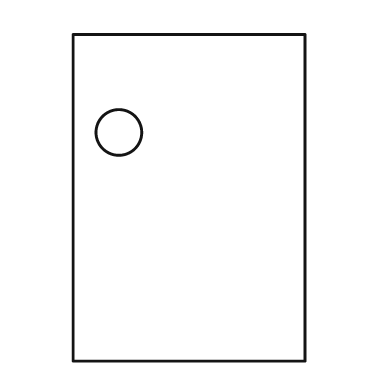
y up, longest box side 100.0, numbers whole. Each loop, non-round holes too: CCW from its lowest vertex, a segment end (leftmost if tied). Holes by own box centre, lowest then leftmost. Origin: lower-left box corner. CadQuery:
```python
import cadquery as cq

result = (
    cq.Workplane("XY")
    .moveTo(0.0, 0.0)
    .lineTo(71.0, 0.0)
    .lineTo(71.0, 100.0)
    .lineTo(0.0, 100.0)
    .close()
    .moveTo(14.0, 70.0)
    .circle(7.0)
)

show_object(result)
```